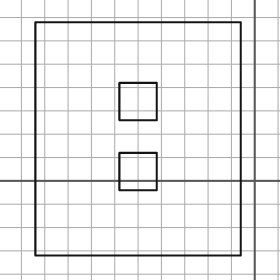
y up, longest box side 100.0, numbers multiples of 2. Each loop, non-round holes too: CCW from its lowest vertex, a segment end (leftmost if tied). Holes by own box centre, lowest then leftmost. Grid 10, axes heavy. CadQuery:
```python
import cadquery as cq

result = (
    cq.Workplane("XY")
    .moveTo(-94.0, -32.0)
    .lineTo(-6.0, -32.0)
    .lineTo(-6.0, 68.0)
    .lineTo(-94.0, 68.0)
    .close()
    .moveTo(-58.0, -4.0)
    .lineTo(-42.0, -4.0)
    .lineTo(-42.0, 12.0)
    .lineTo(-58.0, 12.0)
    .close()
    .moveTo(-58.0, 26.0)
    .lineTo(-42.0, 26.0)
    .lineTo(-42.0, 42.0)
    .lineTo(-58.0, 42.0)
    .close()
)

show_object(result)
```